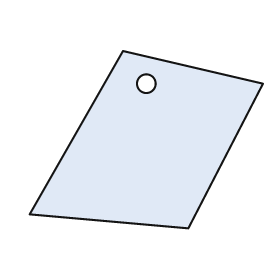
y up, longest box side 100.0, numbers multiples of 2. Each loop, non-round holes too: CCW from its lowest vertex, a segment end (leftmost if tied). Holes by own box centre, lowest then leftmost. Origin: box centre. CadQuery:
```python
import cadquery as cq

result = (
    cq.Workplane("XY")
    .moveTo(18.0, -38.0)
    .lineTo(50.0, 24.0)
    .lineTo(-10.0, 38.0)
    .lineTo(-50.0, -32.0)
    .close()
    .moveTo(0.0, 24.0)
    .circle(4.0)
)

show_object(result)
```